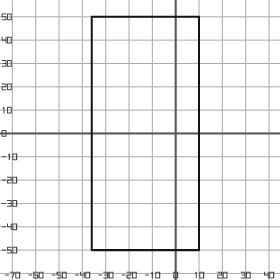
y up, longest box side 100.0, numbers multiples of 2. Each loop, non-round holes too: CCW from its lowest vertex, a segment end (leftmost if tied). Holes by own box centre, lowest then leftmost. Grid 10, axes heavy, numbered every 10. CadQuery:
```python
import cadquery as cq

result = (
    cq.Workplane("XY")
    .moveTo(-36.0, -50.0)
    .lineTo(10.0, -50.0)
    .lineTo(10.0, 50.0)
    .lineTo(-36.0, 50.0)
    .close()
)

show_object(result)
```